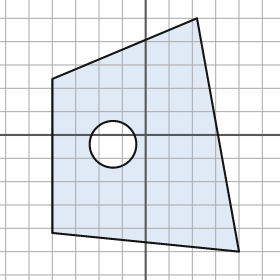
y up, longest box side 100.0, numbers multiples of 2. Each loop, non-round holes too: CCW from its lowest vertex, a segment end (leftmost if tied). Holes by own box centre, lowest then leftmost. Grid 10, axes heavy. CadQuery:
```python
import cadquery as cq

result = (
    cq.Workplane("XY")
    .moveTo(40.0, -50.0)
    .lineTo(22.0, 50.0)
    .lineTo(-40.0, 24.0)
    .lineTo(-40.0, -42.0)
    .close()
    .moveTo(-14.0, -4.0)
    .circle(10.0)
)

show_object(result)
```